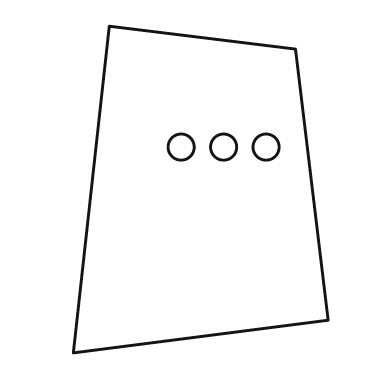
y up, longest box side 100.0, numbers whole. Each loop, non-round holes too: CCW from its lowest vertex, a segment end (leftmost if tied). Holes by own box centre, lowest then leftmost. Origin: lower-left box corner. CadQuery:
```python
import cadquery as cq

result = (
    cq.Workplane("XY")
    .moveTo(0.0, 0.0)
    .lineTo(78.0, 10.0)
    .lineTo(68.0, 93.0)
    .lineTo(11.0, 100.0)
    .close()
    .moveTo(33.0, 63.0)
    .circle(4.0)
    .moveTo(46.0, 63.0)
    .circle(4.0)
    .moveTo(59.0, 63.0)
    .circle(4.0)
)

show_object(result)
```